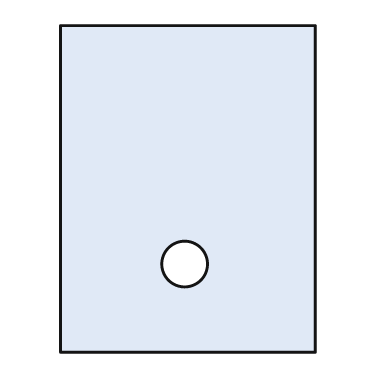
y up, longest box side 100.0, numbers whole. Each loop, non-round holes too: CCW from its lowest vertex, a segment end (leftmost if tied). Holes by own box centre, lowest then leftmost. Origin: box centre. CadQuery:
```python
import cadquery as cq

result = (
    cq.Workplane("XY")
    .moveTo(-39.0, -50.0)
    .lineTo(39.0, -50.0)
    .lineTo(39.0, 50.0)
    .lineTo(-39.0, 50.0)
    .close()
    .moveTo(-1.0, -23.0)
    .circle(7.0)
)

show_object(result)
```